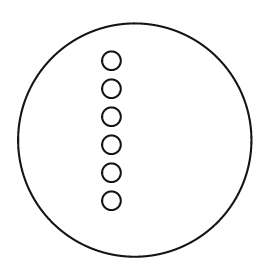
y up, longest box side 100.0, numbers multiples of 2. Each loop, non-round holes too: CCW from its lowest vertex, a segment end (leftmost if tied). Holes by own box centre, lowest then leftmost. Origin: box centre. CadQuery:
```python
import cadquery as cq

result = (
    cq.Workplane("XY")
    .moveTo(0.0, 0.0)
    .circle(50.0)
    .moveTo(-10.0, -26.0)
    .circle(4.0)
    .moveTo(-10.0, -14.0)
    .circle(4.0)
    .moveTo(-10.0, -2.0)
    .circle(4.0)
    .moveTo(-10.0, 10.0)
    .circle(4.0)
    .moveTo(-10.0, 22.0)
    .circle(4.0)
    .moveTo(-10.0, 34.0)
    .circle(4.0)
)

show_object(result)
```